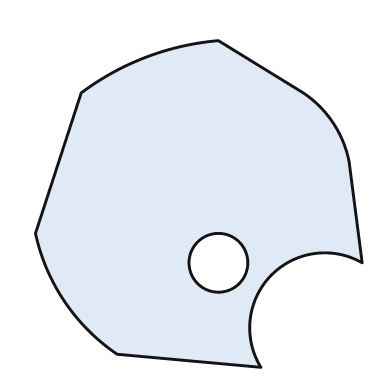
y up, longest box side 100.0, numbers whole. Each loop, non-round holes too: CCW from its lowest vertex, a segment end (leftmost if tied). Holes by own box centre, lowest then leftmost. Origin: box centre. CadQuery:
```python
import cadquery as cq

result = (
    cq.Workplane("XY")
    .moveTo(19.0, -50.0)
    .threePointArc((22.0, -22.0), (50.0, -18.0))
    .lineTo(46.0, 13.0)
    .threePointArc((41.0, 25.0), (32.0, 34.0))
    .lineTo(6.0, 50.0)
    .threePointArc((-16.0, 45.0), (-36.0, 34.0))
    .lineTo(-50.0, -9.0)
    .threePointArc((-41.0, -30.0), (-25.0, -46.0))
    .close()
    .moveTo(6.0, -18.0)
    .circle(9.0)
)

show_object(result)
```